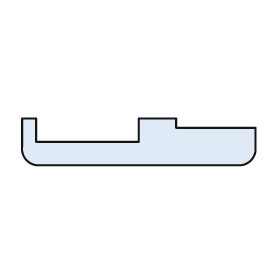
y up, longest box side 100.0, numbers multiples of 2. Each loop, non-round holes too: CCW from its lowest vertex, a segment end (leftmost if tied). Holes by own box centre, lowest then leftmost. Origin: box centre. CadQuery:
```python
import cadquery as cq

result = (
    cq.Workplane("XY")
    .moveTo(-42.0, -10.0)
    .lineTo(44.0, -10.0)
    .threePointArc((48.0, -8.0), (50.0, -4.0))
    .lineTo(50.0, 6.0)
    .lineTo(16.0, 6.0)
    .lineTo(16.0, 10.0)
    .lineTo(0.0, 10.0)
    .lineTo(0.0, 0.0)
    .lineTo(-44.0, 0.0)
    .lineTo(-44.0, 10.0)
    .lineTo(-50.0, 10.0)
    .lineTo(-50.0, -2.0)
    .threePointArc((-48.0, -8.0), (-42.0, -10.0))
    .close()
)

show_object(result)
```